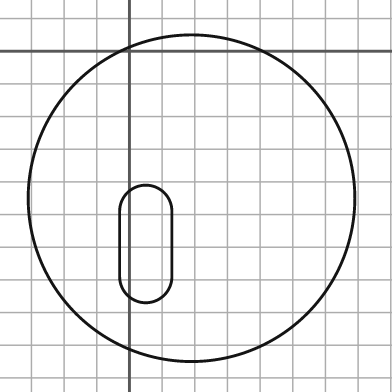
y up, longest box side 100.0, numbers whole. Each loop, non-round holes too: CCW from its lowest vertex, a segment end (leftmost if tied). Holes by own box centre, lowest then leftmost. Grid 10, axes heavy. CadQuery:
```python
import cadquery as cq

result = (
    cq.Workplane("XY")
    .moveTo(19.0, -45.0)
    .circle(50.0)
    .moveTo(-3.0, -69.0)
    .threePointArc((5.0, -77.0), (13.0, -69.0))
    .lineTo(13.0, -49.0)
    .threePointArc((5.0, -41.0), (-3.0, -49.0))
    .close()
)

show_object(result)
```